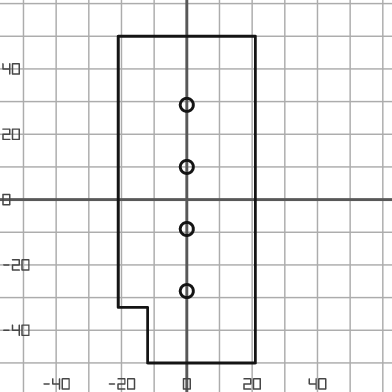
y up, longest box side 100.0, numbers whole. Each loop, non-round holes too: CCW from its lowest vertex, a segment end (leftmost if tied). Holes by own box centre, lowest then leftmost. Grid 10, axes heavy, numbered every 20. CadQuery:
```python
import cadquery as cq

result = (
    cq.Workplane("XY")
    .moveTo(-12.0, -50.0)
    .lineTo(21.0, -50.0)
    .lineTo(21.0, 50.0)
    .lineTo(-21.0, 50.0)
    .lineTo(-21.0, -33.0)
    .lineTo(-12.0, -33.0)
    .close()
    .moveTo(0.0, -28.0)
    .circle(2.0)
    .moveTo(0.0, -9.0)
    .circle(2.0)
    .moveTo(0.0, 10.0)
    .circle(2.0)
    .moveTo(0.0, 29.0)
    .circle(2.0)
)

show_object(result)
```